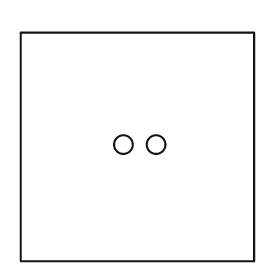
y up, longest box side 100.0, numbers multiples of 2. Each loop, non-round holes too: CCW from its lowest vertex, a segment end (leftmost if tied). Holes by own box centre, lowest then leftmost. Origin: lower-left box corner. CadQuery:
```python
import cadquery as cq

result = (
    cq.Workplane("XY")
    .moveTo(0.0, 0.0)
    .lineTo(100.0, 0.0)
    .lineTo(100.0, 98.0)
    .lineTo(0.0, 98.0)
    .close()
    .moveTo(44.0, 50.0)
    .circle(4.0)
    .moveTo(58.0, 50.0)
    .circle(4.0)
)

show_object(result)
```